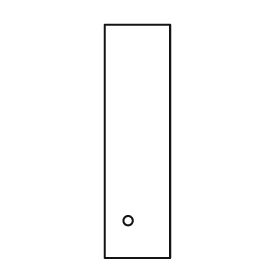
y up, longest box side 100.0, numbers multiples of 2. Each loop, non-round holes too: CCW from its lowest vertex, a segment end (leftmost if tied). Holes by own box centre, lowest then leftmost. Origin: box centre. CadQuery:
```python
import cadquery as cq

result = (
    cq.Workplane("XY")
    .moveTo(-14.0, -50.0)
    .lineTo(14.0, -50.0)
    .lineTo(14.0, 50.0)
    .lineTo(-14.0, 50.0)
    .close()
    .moveTo(-4.0, -34.0)
    .circle(2.0)
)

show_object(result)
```